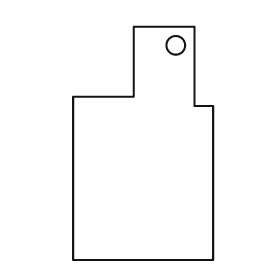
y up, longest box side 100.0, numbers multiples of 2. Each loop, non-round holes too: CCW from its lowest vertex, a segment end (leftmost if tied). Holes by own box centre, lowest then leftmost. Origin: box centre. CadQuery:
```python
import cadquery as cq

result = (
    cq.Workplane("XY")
    .moveTo(-30.0, -50.0)
    .lineTo(30.0, -50.0)
    .lineTo(30.0, 16.0)
    .lineTo(22.0, 16.0)
    .lineTo(22.0, 50.0)
    .lineTo(-4.0, 50.0)
    .lineTo(-4.0, 20.0)
    .lineTo(-30.0, 20.0)
    .close()
    .moveTo(14.0, 42.0)
    .circle(4.0)
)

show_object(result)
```